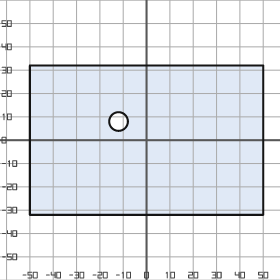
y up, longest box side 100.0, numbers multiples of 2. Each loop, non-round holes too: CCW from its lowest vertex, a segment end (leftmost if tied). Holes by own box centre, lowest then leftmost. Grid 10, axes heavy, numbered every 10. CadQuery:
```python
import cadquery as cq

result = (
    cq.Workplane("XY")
    .moveTo(-50.0, -32.0)
    .lineTo(50.0, -32.0)
    .lineTo(50.0, 32.0)
    .lineTo(-50.0, 32.0)
    .close()
    .moveTo(-12.0, 8.0)
    .circle(4.0)
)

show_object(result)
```